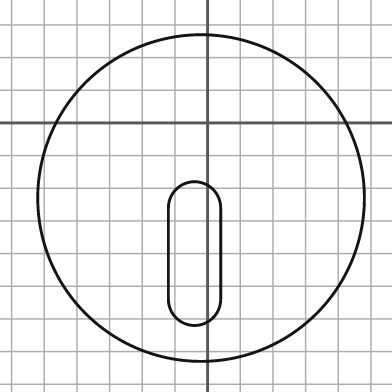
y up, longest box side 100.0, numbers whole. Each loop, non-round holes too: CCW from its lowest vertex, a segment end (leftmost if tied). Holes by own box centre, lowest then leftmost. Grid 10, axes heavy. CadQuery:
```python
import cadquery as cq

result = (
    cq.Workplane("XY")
    .moveTo(-2.0, -23.0)
    .circle(50.0)
    .moveTo(-12.0, -54.0)
    .threePointArc((-4.0, -62.0), (4.0, -54.0))
    .lineTo(4.0, -26.0)
    .threePointArc((-4.0, -18.0), (-12.0, -26.0))
    .close()
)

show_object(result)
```